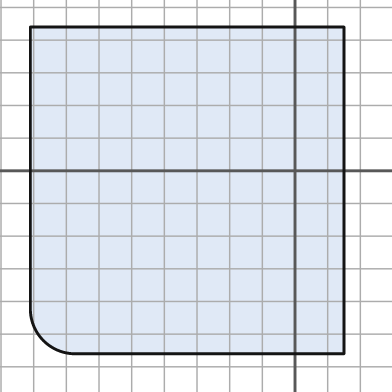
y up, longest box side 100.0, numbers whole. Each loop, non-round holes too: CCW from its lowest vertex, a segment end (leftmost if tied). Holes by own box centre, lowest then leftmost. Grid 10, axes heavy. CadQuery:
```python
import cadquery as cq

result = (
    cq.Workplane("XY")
    .moveTo(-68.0, -56.0)
    .lineTo(15.0, -56.0)
    .lineTo(15.0, 44.0)
    .lineTo(-81.0, 44.0)
    .lineTo(-81.0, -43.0)
    .threePointArc((-77.0, -52.0), (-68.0, -56.0))
    .close()
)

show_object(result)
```